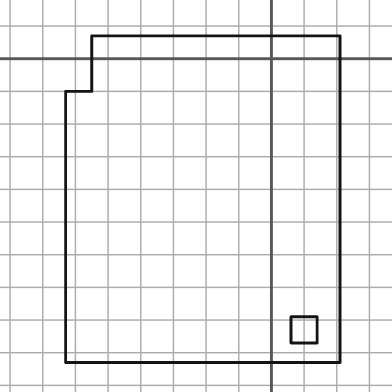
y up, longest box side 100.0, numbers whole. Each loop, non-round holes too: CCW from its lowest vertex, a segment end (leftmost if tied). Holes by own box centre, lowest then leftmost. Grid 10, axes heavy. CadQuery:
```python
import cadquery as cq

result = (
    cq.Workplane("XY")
    .moveTo(-63.0, -93.0)
    .lineTo(21.0, -93.0)
    .lineTo(21.0, 7.0)
    .lineTo(-55.0, 7.0)
    .lineTo(-55.0, -10.0)
    .lineTo(-63.0, -10.0)
    .close()
    .moveTo(6.0, -87.0)
    .lineTo(14.0, -87.0)
    .lineTo(14.0, -79.0)
    .lineTo(6.0, -79.0)
    .close()
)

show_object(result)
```